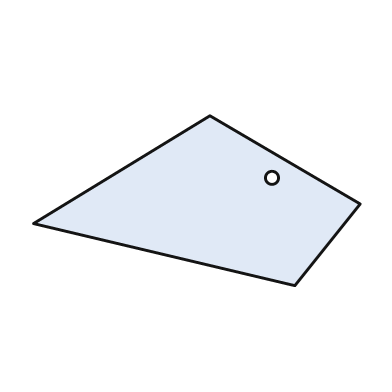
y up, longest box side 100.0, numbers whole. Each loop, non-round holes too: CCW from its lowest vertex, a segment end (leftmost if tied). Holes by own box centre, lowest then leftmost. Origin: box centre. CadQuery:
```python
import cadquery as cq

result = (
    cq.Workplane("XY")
    .moveTo(30.0, -26.0)
    .lineTo(50.0, -1.0)
    .lineTo(4.0, 26.0)
    .lineTo(-50.0, -7.0)
    .close()
    .moveTo(23.0, 7.0)
    .circle(2.0)
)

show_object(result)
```